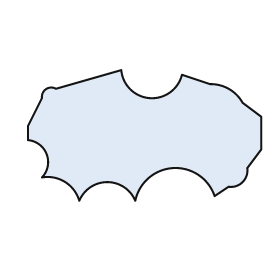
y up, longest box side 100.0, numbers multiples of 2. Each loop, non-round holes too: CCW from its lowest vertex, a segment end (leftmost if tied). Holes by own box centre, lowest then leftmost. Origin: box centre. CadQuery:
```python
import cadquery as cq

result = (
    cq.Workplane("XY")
    .moveTo(-28.0, -28.0)
    .threePointArc((-16.0, -20.0), (-4.0, -28.0))
    .threePointArc((12.0, -14.0), (30.0, -26.0))
    .lineTo(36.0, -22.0)
    .threePointArc((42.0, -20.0), (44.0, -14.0))
    .lineTo(50.0, -6.0)
    .lineTo(50.0, 8.0)
    .lineTo(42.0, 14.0)
    .threePointArc((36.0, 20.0), (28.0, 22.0))
    .lineTo(16.0, 26.0)
    .threePointArc((2.0, 16.0), (-10.0, 28.0))
    .lineTo(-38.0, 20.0)
    .threePointArc((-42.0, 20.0), (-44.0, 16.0))
    .lineTo(-50.0, 4.0)
    .lineTo(-50.0, -2.0)
    .threePointArc((-42.0, -8.0), (-44.0, -18.0))
    .threePointArc((-34.0, -20.0), (-28.0, -28.0))
    .close()
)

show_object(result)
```